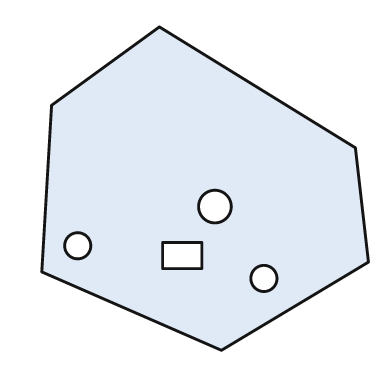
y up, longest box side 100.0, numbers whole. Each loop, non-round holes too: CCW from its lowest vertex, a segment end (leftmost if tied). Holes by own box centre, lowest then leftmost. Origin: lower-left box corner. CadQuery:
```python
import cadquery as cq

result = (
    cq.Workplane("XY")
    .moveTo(55.0, 0.0)
    .lineTo(100.0, 27.0)
    .lineTo(96.0, 62.0)
    .lineTo(36.0, 99.0)
    .lineTo(3.0, 75.0)
    .lineTo(0.0, 24.0)
    .close()
    .moveTo(68.0, 22.0)
    .circle(4.0)
    .moveTo(37.0, 25.0)
    .lineTo(49.0, 25.0)
    .lineTo(49.0, 33.0)
    .lineTo(37.0, 33.0)
    .close()
    .moveTo(11.0, 32.0)
    .circle(4.0)
    .moveTo(53.0, 44.0)
    .circle(5.0)
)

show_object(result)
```